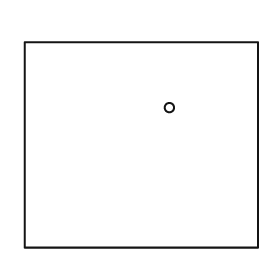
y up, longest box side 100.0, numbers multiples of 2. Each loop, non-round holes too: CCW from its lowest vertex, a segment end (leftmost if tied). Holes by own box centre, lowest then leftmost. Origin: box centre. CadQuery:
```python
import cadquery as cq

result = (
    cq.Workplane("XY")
    .moveTo(-50.0, -44.0)
    .lineTo(50.0, -44.0)
    .lineTo(50.0, 44.0)
    .lineTo(-50.0, 44.0)
    .close()
    .moveTo(12.0, 16.0)
    .circle(2.0)
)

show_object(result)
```